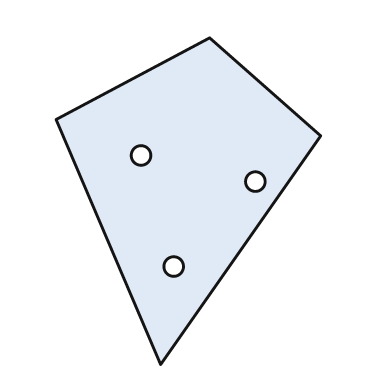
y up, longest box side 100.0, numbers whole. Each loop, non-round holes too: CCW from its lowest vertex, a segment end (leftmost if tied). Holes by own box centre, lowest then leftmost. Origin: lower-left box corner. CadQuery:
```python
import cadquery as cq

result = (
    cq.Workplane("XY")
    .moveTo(32.0, 0.0)
    .lineTo(81.0, 70.0)
    .lineTo(47.0, 100.0)
    .lineTo(0.0, 75.0)
    .close()
    .moveTo(36.0, 30.0)
    .circle(3.0)
    .moveTo(61.0, 56.0)
    .circle(3.0)
    .moveTo(26.0, 64.0)
    .circle(3.0)
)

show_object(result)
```